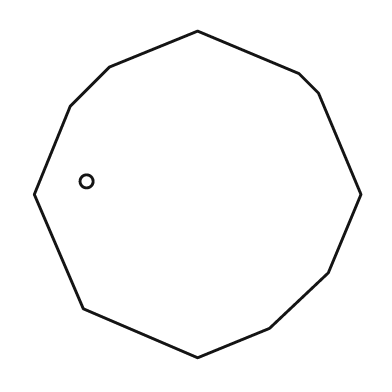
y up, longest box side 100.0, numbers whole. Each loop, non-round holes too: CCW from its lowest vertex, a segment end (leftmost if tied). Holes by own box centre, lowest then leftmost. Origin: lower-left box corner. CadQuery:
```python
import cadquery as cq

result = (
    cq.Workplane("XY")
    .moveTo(50.0, 0.0)
    .lineTo(72.0, 9.0)
    .lineTo(90.0, 26.0)
    .lineTo(100.0, 50.0)
    .lineTo(87.0, 81.0)
    .lineTo(81.0, 87.0)
    .lineTo(50.0, 100.0)
    .lineTo(23.0, 89.0)
    .lineTo(11.0, 77.0)
    .lineTo(0.0, 50.0)
    .lineTo(15.0, 15.0)
    .close()
    .moveTo(16.0, 54.0)
    .circle(2.0)
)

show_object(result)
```